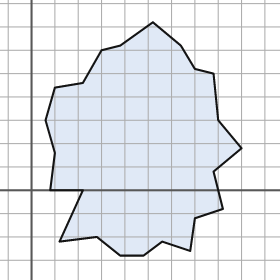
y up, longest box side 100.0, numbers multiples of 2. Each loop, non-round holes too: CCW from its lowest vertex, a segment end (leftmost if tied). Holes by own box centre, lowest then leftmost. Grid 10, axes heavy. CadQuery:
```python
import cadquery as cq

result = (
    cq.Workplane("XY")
    .moveTo(38.0, -28.0)
    .lineTo(48.0, -28.0)
    .lineTo(56.0, -22.0)
    .lineTo(68.0, -26.0)
    .lineTo(70.0, -12.0)
    .lineTo(82.0, -8.0)
    .lineTo(78.0, 8.0)
    .lineTo(90.0, 18.0)
    .lineTo(80.0, 30.0)
    .lineTo(78.0, 50.0)
    .lineTo(70.0, 52.0)
    .lineTo(64.0, 62.0)
    .lineTo(52.0, 72.0)
    .lineTo(38.0, 62.0)
    .lineTo(30.0, 60.0)
    .lineTo(22.0, 46.0)
    .lineTo(10.0, 44.0)
    .lineTo(6.0, 30.0)
    .lineTo(10.0, 16.0)
    .lineTo(8.0, 0.0)
    .lineTo(22.0, 0.0)
    .lineTo(12.0, -22.0)
    .lineTo(28.0, -20.0)
    .close()
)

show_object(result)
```